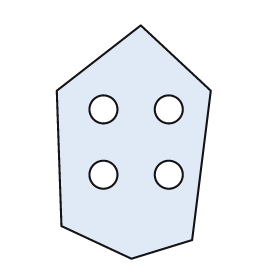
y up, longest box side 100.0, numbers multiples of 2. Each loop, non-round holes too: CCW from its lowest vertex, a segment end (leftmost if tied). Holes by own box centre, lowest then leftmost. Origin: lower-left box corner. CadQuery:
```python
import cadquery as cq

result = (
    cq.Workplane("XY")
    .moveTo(32.0, 0.0)
    .lineTo(58.0, 8.0)
    .lineTo(66.0, 72.0)
    .lineTo(36.0, 100.0)
    .lineTo(0.0, 72.0)
    .lineTo(2.0, 14.0)
    .close()
    .moveTo(20.0, 36.0)
    .circle(6.0)
    .moveTo(48.0, 36.0)
    .circle(6.0)
    .moveTo(20.0, 64.0)
    .circle(6.0)
    .moveTo(48.0, 64.0)
    .circle(6.0)
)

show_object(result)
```